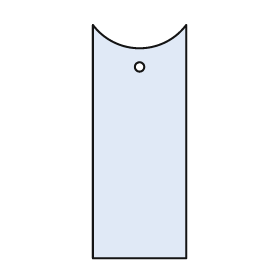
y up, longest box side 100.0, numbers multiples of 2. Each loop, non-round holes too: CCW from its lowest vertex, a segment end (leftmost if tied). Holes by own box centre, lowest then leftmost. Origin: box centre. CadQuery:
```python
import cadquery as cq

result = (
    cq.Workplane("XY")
    .moveTo(-20.0, -50.0)
    .lineTo(20.0, -50.0)
    .lineTo(20.0, 50.0)
    .threePointArc((0.0, 40.0), (-20.0, 50.0))
    .close()
    .moveTo(0.0, 32.0)
    .circle(2.0)
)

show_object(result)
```